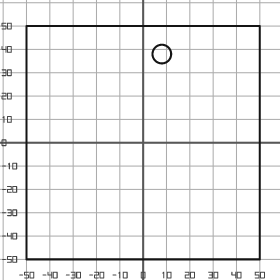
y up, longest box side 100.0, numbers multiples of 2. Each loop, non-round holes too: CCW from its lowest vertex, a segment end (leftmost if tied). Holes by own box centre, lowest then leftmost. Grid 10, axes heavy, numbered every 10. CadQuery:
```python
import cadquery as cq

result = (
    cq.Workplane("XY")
    .moveTo(-50.0, -50.0)
    .lineTo(50.0, -50.0)
    .lineTo(50.0, 50.0)
    .lineTo(-50.0, 50.0)
    .close()
    .moveTo(8.0, 38.0)
    .circle(4.0)
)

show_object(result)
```